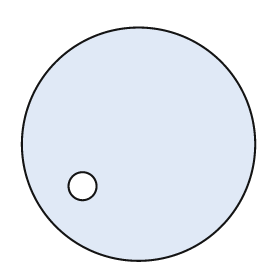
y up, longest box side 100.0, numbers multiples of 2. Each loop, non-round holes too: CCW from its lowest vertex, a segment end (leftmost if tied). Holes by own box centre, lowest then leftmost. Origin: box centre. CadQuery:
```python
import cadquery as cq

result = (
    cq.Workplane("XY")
    .moveTo(0.0, 0.0)
    .circle(50.0)
    .moveTo(-24.0, -18.0)
    .circle(6.0)
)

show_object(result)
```